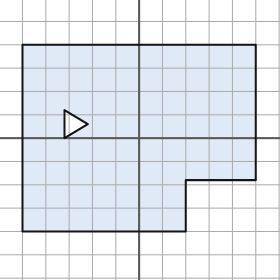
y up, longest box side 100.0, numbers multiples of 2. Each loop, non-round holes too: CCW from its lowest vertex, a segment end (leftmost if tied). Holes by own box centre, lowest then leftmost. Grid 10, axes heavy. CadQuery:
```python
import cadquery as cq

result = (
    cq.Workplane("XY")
    .moveTo(-50.0, -40.0)
    .lineTo(20.0, -40.0)
    .lineTo(20.0, -18.0)
    .lineTo(50.0, -18.0)
    .lineTo(50.0, 40.0)
    .lineTo(-50.0, 40.0)
    .close()
    .moveTo(-32.0, 0.0)
    .lineTo(-22.0, 6.0)
    .lineTo(-32.0, 12.0)
    .close()
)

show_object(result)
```